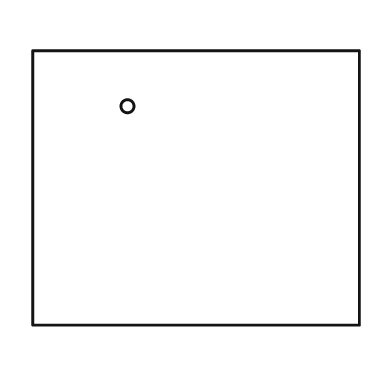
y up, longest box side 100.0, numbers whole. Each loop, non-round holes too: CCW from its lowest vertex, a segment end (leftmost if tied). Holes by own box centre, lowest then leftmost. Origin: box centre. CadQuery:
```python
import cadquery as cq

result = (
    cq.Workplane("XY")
    .moveTo(-50.0, -42.0)
    .lineTo(50.0, -42.0)
    .lineTo(50.0, 42.0)
    .lineTo(-50.0, 42.0)
    .close()
    .moveTo(-21.0, 25.0)
    .circle(2.0)
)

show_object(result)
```